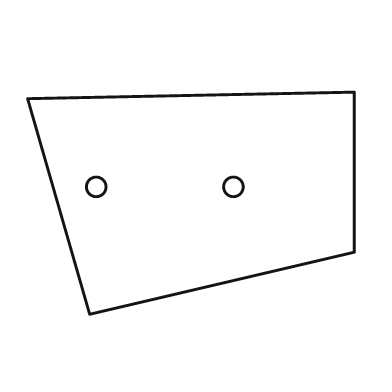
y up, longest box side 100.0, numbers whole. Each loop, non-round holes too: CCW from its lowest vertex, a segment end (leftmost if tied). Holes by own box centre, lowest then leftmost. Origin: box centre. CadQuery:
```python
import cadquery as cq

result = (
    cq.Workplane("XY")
    .moveTo(-31.0, -34.0)
    .lineTo(50.0, -15.0)
    .lineTo(50.0, 34.0)
    .lineTo(-50.0, 32.0)
    .close()
    .moveTo(-29.0, 5.0)
    .circle(3.0)
    .moveTo(13.0, 5.0)
    .circle(3.0)
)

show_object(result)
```